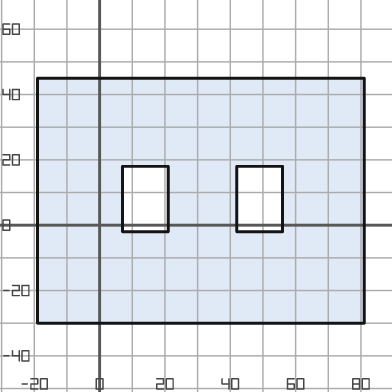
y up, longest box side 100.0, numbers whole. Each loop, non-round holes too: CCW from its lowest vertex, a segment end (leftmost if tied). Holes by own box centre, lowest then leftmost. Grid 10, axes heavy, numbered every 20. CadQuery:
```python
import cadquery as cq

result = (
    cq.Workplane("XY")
    .moveTo(-19.0, -30.0)
    .lineTo(81.0, -30.0)
    .lineTo(81.0, 45.0)
    .lineTo(-19.0, 45.0)
    .close()
    .moveTo(7.0, -2.0)
    .lineTo(21.0, -2.0)
    .lineTo(21.0, 18.0)
    .lineTo(7.0, 18.0)
    .close()
    .moveTo(42.0, -2.0)
    .lineTo(56.0, -2.0)
    .lineTo(56.0, 18.0)
    .lineTo(42.0, 18.0)
    .close()
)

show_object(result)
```